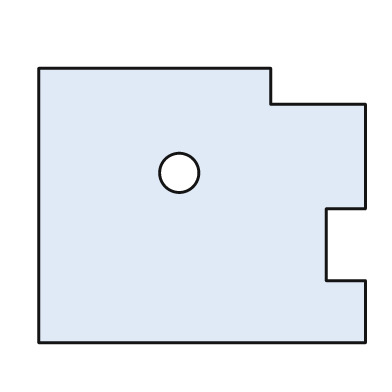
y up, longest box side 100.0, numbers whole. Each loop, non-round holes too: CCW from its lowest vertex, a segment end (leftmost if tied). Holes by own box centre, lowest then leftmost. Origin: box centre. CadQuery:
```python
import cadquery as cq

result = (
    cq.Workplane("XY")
    .moveTo(-50.0, -42.0)
    .lineTo(50.0, -42.0)
    .lineTo(50.0, -23.0)
    .lineTo(38.0, -23.0)
    .lineTo(38.0, -1.0)
    .lineTo(50.0, -1.0)
    .lineTo(50.0, 31.0)
    .lineTo(21.0, 31.0)
    .lineTo(21.0, 42.0)
    .lineTo(-50.0, 42.0)
    .close()
    .moveTo(-7.0, 10.0)
    .circle(6.0)
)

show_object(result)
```